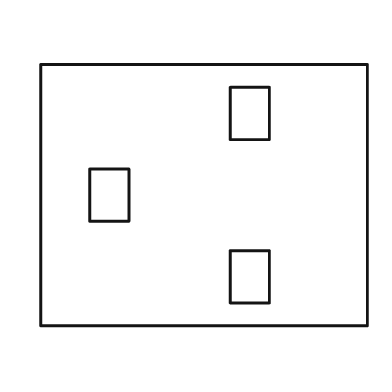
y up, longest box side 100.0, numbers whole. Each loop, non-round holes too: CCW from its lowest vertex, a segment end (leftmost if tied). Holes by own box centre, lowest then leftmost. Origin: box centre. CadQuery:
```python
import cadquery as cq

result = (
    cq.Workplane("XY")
    .moveTo(-50.0, -40.0)
    .lineTo(50.0, -40.0)
    .lineTo(50.0, 40.0)
    .lineTo(-50.0, 40.0)
    .close()
    .moveTo(8.0, -33.0)
    .lineTo(20.0, -33.0)
    .lineTo(20.0, -17.0)
    .lineTo(8.0, -17.0)
    .close()
    .moveTo(-35.0, -8.0)
    .lineTo(-23.0, -8.0)
    .lineTo(-23.0, 8.0)
    .lineTo(-35.0, 8.0)
    .close()
    .moveTo(8.0, 17.0)
    .lineTo(20.0, 17.0)
    .lineTo(20.0, 33.0)
    .lineTo(8.0, 33.0)
    .close()
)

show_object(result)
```